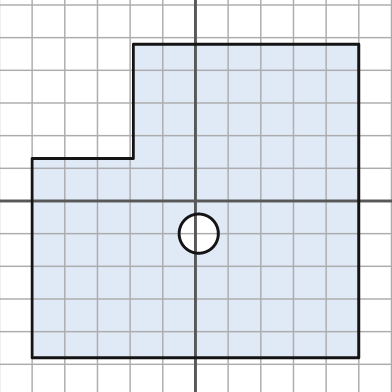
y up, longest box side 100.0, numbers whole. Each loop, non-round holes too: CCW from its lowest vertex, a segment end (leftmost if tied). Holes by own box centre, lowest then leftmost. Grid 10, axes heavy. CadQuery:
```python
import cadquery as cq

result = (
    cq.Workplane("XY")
    .moveTo(-50.0, -48.0)
    .lineTo(50.0, -48.0)
    .lineTo(50.0, 48.0)
    .lineTo(-19.0, 48.0)
    .lineTo(-19.0, 13.0)
    .lineTo(-50.0, 13.0)
    .close()
    .moveTo(1.0, -10.0)
    .circle(6.0)
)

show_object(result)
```